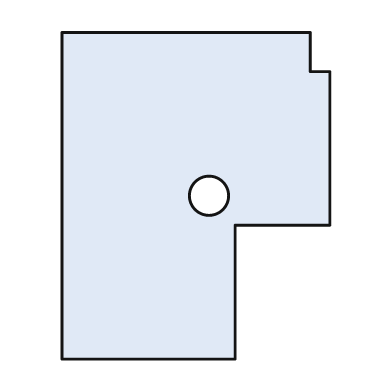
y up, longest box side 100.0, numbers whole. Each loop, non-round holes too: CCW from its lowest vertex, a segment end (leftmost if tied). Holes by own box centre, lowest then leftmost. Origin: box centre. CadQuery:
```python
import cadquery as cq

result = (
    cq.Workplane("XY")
    .moveTo(-41.0, -50.0)
    .lineTo(12.0, -50.0)
    .lineTo(12.0, -9.0)
    .lineTo(41.0, -9.0)
    .lineTo(41.0, 38.0)
    .lineTo(35.0, 38.0)
    .lineTo(35.0, 50.0)
    .lineTo(-41.0, 50.0)
    .close()
    .moveTo(4.0, 0.0)
    .circle(6.0)
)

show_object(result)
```